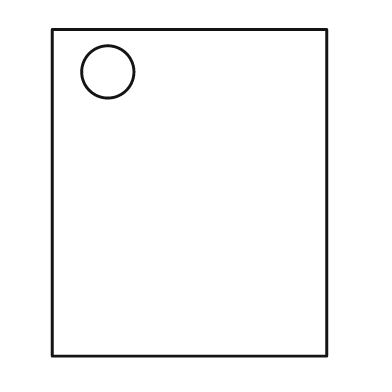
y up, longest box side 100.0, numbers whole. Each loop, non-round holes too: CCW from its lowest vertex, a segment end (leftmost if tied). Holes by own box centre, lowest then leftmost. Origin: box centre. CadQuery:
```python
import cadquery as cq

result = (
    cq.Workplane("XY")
    .moveTo(-42.0, -50.0)
    .lineTo(42.0, -50.0)
    .lineTo(42.0, 50.0)
    .lineTo(-42.0, 50.0)
    .close()
    .moveTo(-25.0, 37.0)
    .circle(8.0)
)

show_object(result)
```